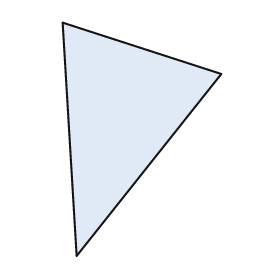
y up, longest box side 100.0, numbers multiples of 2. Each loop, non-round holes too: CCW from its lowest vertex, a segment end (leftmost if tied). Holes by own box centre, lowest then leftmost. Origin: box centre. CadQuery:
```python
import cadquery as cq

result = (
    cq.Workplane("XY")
    .moveTo(-28.0, -50.0)
    .lineTo(34.0, 28.0)
    .lineTo(-34.0, 50.0)
    .close()
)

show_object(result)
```